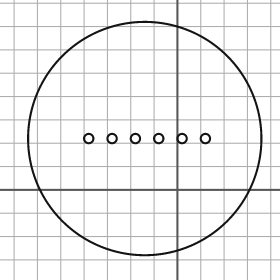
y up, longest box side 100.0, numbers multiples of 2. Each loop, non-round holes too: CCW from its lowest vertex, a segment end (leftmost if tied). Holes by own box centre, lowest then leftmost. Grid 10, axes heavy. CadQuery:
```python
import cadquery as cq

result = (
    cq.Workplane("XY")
    .moveTo(-14.0, 22.0)
    .circle(50.0)
    .moveTo(-38.0, 22.0)
    .circle(2.0)
    .moveTo(-28.0, 22.0)
    .circle(2.0)
    .moveTo(-18.0, 22.0)
    .circle(2.0)
    .moveTo(-8.0, 22.0)
    .circle(2.0)
    .moveTo(2.0, 22.0)
    .circle(2.0)
    .moveTo(12.0, 22.0)
    .circle(2.0)
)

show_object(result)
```